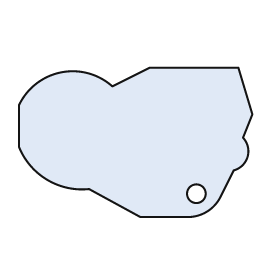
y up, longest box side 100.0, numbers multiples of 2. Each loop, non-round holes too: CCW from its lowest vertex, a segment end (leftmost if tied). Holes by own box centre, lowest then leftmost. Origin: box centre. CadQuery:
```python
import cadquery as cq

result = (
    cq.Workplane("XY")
    .moveTo(2.0, -32.0)
    .lineTo(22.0, -32.0)
    .threePointArc((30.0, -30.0), (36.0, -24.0))
    .lineTo(42.0, -12.0)
    .threePointArc((48.0, -6.0), (46.0, 2.0))
    .lineTo(50.0, 12.0)
    .lineTo(44.0, 32.0)
    .lineTo(6.0, 32.0)
    .lineTo(-10.0, 24.0)
    .threePointArc((-32.0, 30.0), (-50.0, 16.0))
    .lineTo(-50.0, -2.0)
    .threePointArc((-38.0, -16.0), (-20.0, -20.0))
    .close()
    .moveTo(26.0, -22.0)
    .circle(4.0)
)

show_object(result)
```